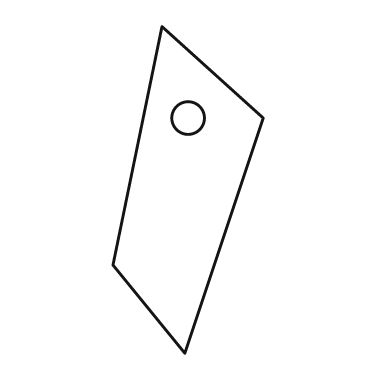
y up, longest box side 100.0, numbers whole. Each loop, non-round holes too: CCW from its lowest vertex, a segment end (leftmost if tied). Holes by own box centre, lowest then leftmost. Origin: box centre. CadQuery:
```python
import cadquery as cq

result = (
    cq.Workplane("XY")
    .moveTo(-1.0, -50.0)
    .lineTo(23.0, 22.0)
    .lineTo(-8.0, 50.0)
    .lineTo(-23.0, -23.0)
    .close()
    .moveTo(0.0, 22.0)
    .circle(5.0)
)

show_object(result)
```